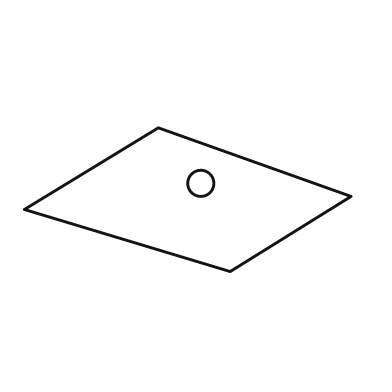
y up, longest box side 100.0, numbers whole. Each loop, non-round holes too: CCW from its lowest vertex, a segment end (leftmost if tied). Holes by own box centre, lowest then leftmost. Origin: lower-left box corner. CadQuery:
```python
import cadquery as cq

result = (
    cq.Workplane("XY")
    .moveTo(63.0, 0.0)
    .lineTo(100.0, 23.0)
    .lineTo(41.0, 44.0)
    .lineTo(0.0, 19.0)
    .close()
    .moveTo(54.0, 27.0)
    .circle(4.0)
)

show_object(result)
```